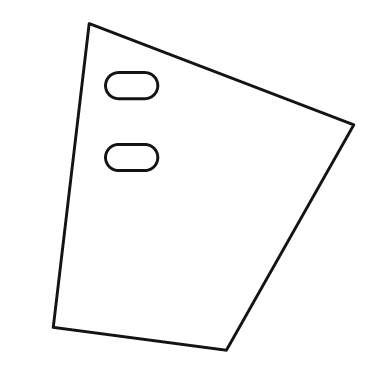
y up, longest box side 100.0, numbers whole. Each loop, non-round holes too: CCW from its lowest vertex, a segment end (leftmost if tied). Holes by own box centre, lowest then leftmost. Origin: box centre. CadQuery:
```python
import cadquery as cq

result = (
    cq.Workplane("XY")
    .moveTo(7.0, -50.0)
    .lineTo(46.0, 19.0)
    .lineTo(-35.0, 50.0)
    .lineTo(-46.0, -43.0)
    .close()
    .moveTo(-26.0, 5.0)
    .lineTo(-18.0, 5.0)
    .threePointArc((-14.0, 9.0), (-18.0, 13.0))
    .lineTo(-26.0, 13.0)
    .threePointArc((-30.0, 9.0), (-26.0, 5.0))
    .close()
    .moveTo(-26.0, 27.0)
    .lineTo(-18.0, 27.0)
    .threePointArc((-14.0, 31.0), (-18.0, 35.0))
    .lineTo(-26.0, 35.0)
    .threePointArc((-30.0, 31.0), (-26.0, 27.0))
    .close()
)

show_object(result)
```